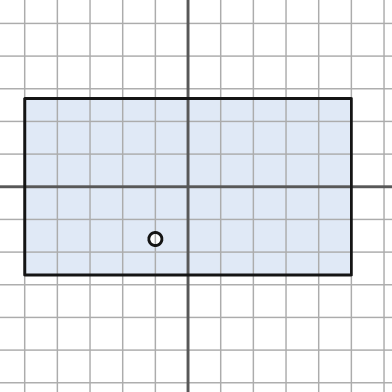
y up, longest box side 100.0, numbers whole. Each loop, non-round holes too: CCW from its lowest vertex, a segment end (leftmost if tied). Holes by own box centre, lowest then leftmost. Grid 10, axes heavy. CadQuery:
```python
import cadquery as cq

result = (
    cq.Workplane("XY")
    .moveTo(-50.0, -27.0)
    .lineTo(50.0, -27.0)
    .lineTo(50.0, 27.0)
    .lineTo(-50.0, 27.0)
    .close()
    .moveTo(-10.0, -16.0)
    .circle(2.0)
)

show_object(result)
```